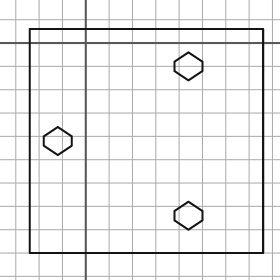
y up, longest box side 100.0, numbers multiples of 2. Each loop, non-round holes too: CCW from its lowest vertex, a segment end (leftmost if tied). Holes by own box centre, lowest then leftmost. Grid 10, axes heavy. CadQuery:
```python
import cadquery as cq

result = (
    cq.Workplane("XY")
    .moveTo(-24.0, -90.0)
    .lineTo(76.0, -90.0)
    .lineTo(76.0, 6.0)
    .lineTo(-24.0, 6.0)
    .close()
    .moveTo(44.0, -80.0)
    .lineTo(50.0, -76.0)
    .lineTo(50.0, -72.0)
    .lineTo(44.0, -68.0)
    .lineTo(38.0, -72.0)
    .lineTo(38.0, -76.0)
    .close()
    .moveTo(-12.0, -48.0)
    .lineTo(-6.0, -44.0)
    .lineTo(-6.0, -40.0)
    .lineTo(-12.0, -36.0)
    .lineTo(-18.0, -40.0)
    .lineTo(-18.0, -44.0)
    .close()
    .moveTo(44.0, -16.0)
    .lineTo(50.0, -12.0)
    .lineTo(50.0, -8.0)
    .lineTo(44.0, -4.0)
    .lineTo(38.0, -8.0)
    .lineTo(38.0, -12.0)
    .close()
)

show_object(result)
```